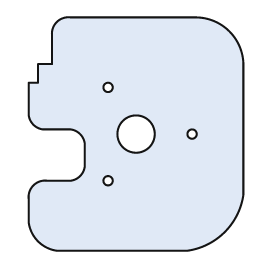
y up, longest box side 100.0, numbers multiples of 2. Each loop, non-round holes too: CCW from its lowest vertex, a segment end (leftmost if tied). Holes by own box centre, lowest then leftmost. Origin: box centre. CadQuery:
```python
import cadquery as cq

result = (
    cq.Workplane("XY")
    .moveTo(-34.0, -50.0)
    .lineTo(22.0, -50.0)
    .threePointArc((38.0, -42.0), (46.0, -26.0))
    .lineTo(46.0, 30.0)
    .threePointArc((40.0, 44.0), (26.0, 50.0))
    .lineTo(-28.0, 50.0)
    .threePointArc((-34.0, 48.0), (-36.0, 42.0))
    .lineTo(-36.0, 30.0)
    .lineTo(-42.0, 30.0)
    .lineTo(-42.0, 22.0)
    .lineTo(-46.0, 22.0)
    .lineTo(-46.0, 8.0)
    .threePointArc((-44.0, 4.0), (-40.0, 2.0))
    .lineTo(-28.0, 2.0)
    .threePointArc((-24.0, 0.0), (-22.0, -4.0))
    .lineTo(-22.0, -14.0)
    .threePointArc((-24.0, -18.0), (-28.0, -20.0))
    .lineTo(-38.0, -20.0)
    .threePointArc((-44.0, -22.0), (-46.0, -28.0))
    .lineTo(-46.0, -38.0)
    .threePointArc((-42.0, -46.0), (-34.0, -50.0))
    .close()
    .moveTo(-12.0, -20.0)
    .circle(2.0)
    .moveTo(0.0, 0.0)
    .circle(8.0)
    .moveTo(24.0, 0.0)
    .circle(2.0)
    .moveTo(-12.0, 20.0)
    .circle(2.0)
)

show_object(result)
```